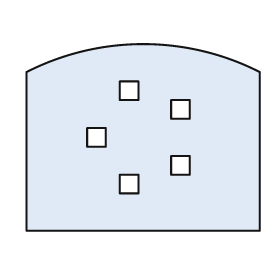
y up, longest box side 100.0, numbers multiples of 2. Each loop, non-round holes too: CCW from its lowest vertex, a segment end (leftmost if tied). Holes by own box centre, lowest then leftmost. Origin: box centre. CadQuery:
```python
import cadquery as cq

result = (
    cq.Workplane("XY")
    .moveTo(-50.0, -40.0)
    .lineTo(50.0, -40.0)
    .lineTo(50.0, 28.0)
    .threePointArc((0.0, 40.0), (-50.0, 28.0))
    .close()
    .moveTo(-10.0, -24.0)
    .lineTo(-2.0, -24.0)
    .lineTo(-2.0, -16.0)
    .lineTo(-10.0, -16.0)
    .close()
    .moveTo(12.0, -16.0)
    .lineTo(20.0, -16.0)
    .lineTo(20.0, -8.0)
    .lineTo(12.0, -8.0)
    .close()
    .moveTo(-24.0, -4.0)
    .lineTo(-16.0, -4.0)
    .lineTo(-16.0, 4.0)
    .lineTo(-24.0, 4.0)
    .close()
    .moveTo(12.0, 8.0)
    .lineTo(20.0, 8.0)
    .lineTo(20.0, 16.0)
    .lineTo(12.0, 16.0)
    .close()
    .moveTo(-10.0, 16.0)
    .lineTo(-2.0, 16.0)
    .lineTo(-2.0, 24.0)
    .lineTo(-10.0, 24.0)
    .close()
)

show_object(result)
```